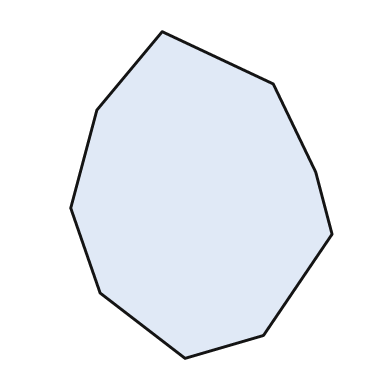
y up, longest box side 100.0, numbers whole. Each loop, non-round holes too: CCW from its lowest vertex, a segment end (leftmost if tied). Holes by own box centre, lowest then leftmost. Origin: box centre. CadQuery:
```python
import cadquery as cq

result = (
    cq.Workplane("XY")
    .moveTo(-5.0, -50.0)
    .lineTo(19.0, -43.0)
    .lineTo(40.0, -12.0)
    .lineTo(35.0, 7.0)
    .lineTo(22.0, 34.0)
    .lineTo(-12.0, 50.0)
    .lineTo(-32.0, 26.0)
    .lineTo(-40.0, -4.0)
    .lineTo(-31.0, -30.0)
    .close()
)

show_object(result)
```